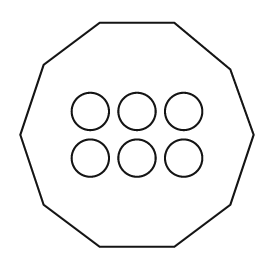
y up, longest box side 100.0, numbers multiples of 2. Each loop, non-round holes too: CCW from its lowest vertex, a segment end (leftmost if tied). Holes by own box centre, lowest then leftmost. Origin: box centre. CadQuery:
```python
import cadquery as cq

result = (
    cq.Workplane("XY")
    .moveTo(-16.0, -48.0)
    .lineTo(16.0, -48.0)
    .lineTo(40.0, -30.0)
    .lineTo(50.0, 0.0)
    .lineTo(40.0, 28.0)
    .lineTo(16.0, 48.0)
    .lineTo(-16.0, 48.0)
    .lineTo(-40.0, 30.0)
    .lineTo(-50.0, 0.0)
    .lineTo(-40.0, -30.0)
    .close()
    .moveTo(-20.0, -10.0)
    .circle(8.0)
    .moveTo(0.0, -10.0)
    .circle(8.0)
    .moveTo(20.0, -10.0)
    .circle(8.0)
    .moveTo(-20.0, 10.0)
    .circle(8.0)
    .moveTo(0.0, 10.0)
    .circle(8.0)
    .moveTo(20.0, 10.0)
    .circle(8.0)
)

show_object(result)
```